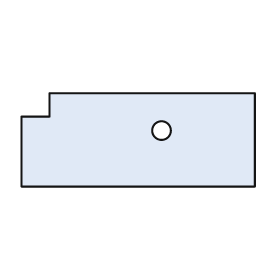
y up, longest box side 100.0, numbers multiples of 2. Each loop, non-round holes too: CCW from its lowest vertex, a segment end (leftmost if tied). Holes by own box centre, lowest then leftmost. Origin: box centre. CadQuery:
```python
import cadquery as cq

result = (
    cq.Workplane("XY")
    .moveTo(-50.0, -20.0)
    .lineTo(50.0, -20.0)
    .lineTo(50.0, 20.0)
    .lineTo(-38.0, 20.0)
    .lineTo(-38.0, 10.0)
    .lineTo(-50.0, 10.0)
    .close()
    .moveTo(10.0, 4.0)
    .circle(4.0)
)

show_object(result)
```